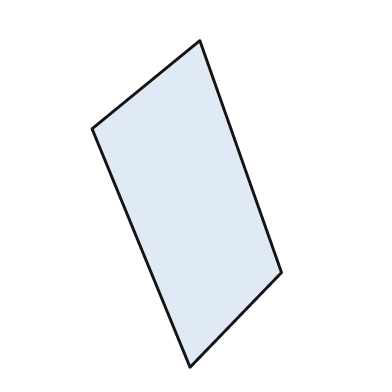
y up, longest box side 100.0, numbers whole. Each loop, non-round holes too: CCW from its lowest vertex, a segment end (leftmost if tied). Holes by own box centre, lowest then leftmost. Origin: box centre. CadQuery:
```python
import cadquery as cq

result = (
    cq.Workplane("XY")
    .moveTo(1.0, -50.0)
    .lineTo(29.0, -21.0)
    .lineTo(4.0, 50.0)
    .lineTo(-29.0, 23.0)
    .close()
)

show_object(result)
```